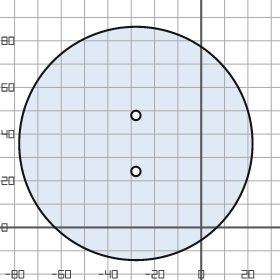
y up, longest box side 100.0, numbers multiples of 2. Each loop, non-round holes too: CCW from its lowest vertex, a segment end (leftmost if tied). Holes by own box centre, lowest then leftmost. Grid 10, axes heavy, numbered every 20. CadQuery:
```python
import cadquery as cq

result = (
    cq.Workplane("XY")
    .moveTo(-28.0, 36.0)
    .circle(50.0)
    .moveTo(-28.0, 24.0)
    .circle(2.0)
    .moveTo(-28.0, 48.0)
    .circle(2.0)
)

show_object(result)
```